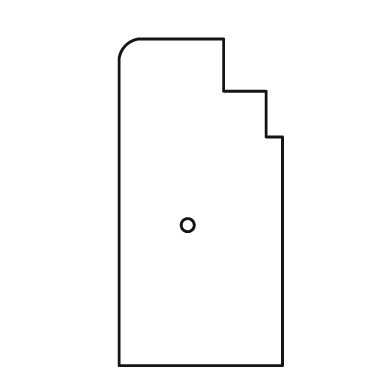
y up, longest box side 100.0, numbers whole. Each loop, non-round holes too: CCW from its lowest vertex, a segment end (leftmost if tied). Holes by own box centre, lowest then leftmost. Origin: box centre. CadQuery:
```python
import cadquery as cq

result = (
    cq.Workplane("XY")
    .moveTo(-25.0, -50.0)
    .lineTo(25.0, -50.0)
    .lineTo(25.0, 20.0)
    .lineTo(20.0, 20.0)
    .lineTo(20.0, 34.0)
    .lineTo(7.0, 34.0)
    .lineTo(7.0, 50.0)
    .lineTo(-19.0, 50.0)
    .threePointArc((-23.0, 48.0), (-25.0, 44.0))
    .close()
    .moveTo(-4.0, -7.0)
    .circle(2.0)
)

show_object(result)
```